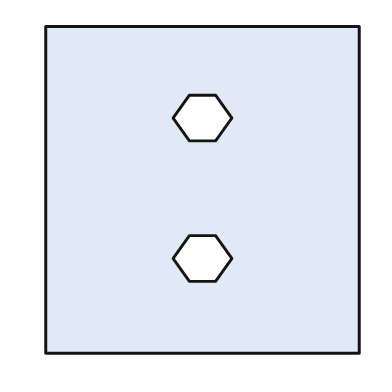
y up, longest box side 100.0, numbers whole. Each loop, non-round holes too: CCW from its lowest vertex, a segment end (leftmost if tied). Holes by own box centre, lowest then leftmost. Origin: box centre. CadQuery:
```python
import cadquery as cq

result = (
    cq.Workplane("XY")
    .moveTo(-48.0, -50.0)
    .lineTo(48.0, -50.0)
    .lineTo(48.0, 50.0)
    .lineTo(-48.0, 50.0)
    .close()
    .moveTo(-4.0, -28.0)
    .lineTo(4.0, -28.0)
    .lineTo(9.0, -21.0)
    .lineTo(4.0, -14.0)
    .lineTo(-4.0, -14.0)
    .lineTo(-9.0, -21.0)
    .close()
    .moveTo(-4.0, 15.0)
    .lineTo(4.0, 15.0)
    .lineTo(9.0, 22.0)
    .lineTo(4.0, 29.0)
    .lineTo(-4.0, 29.0)
    .lineTo(-9.0, 22.0)
    .close()
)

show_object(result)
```